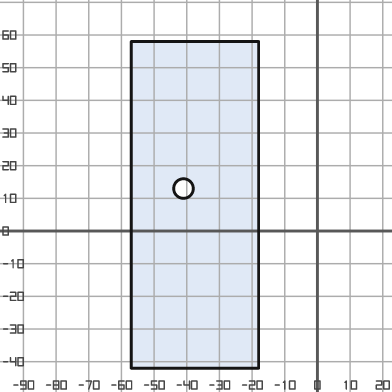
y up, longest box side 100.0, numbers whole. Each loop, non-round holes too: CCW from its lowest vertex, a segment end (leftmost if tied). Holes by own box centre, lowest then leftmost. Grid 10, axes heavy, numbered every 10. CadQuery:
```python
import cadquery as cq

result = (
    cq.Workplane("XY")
    .moveTo(-57.0, -42.0)
    .lineTo(-18.0, -42.0)
    .lineTo(-18.0, 58.0)
    .lineTo(-57.0, 58.0)
    .close()
    .moveTo(-41.0, 13.0)
    .circle(3.0)
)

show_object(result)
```